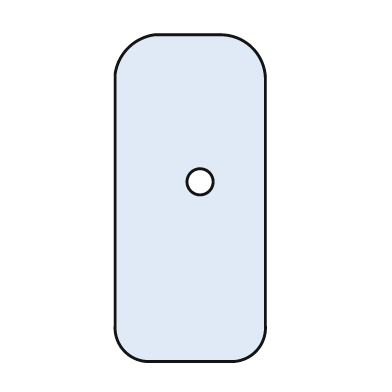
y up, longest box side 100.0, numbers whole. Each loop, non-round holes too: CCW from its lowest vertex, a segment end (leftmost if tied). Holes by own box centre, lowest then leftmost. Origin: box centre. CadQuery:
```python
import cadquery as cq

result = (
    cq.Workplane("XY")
    .moveTo(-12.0, -50.0)
    .lineTo(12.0, -50.0)
    .threePointArc((20.0, -47.0), (23.0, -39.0))
    .lineTo(23.0, 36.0)
    .threePointArc((19.0, 46.0), (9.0, 50.0))
    .lineTo(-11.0, 50.0)
    .threePointArc((-19.0, 46.0), (-23.0, 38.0))
    .lineTo(-23.0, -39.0)
    .threePointArc((-20.0, -47.0), (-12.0, -50.0))
    .close()
    .moveTo(3.0, 5.0)
    .circle(4.0)
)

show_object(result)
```